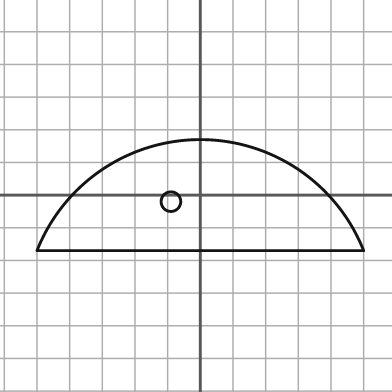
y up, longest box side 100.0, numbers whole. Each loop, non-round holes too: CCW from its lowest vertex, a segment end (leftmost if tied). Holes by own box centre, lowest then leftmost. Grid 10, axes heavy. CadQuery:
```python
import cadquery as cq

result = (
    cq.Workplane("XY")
    .moveTo(-50.0, -17.0)
    .lineTo(50.0, -17.0)
    .threePointArc((0.0, 17.0), (-50.0, -17.0))
    .close()
    .moveTo(-9.0, -2.0)
    .circle(3.0)
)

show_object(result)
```